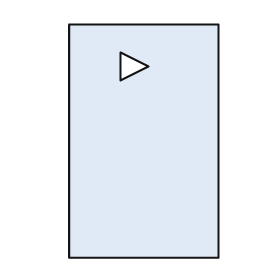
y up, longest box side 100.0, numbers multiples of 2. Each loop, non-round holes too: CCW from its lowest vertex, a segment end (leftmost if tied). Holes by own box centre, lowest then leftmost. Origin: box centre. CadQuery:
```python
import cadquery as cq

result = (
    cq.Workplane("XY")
    .moveTo(-32.0, -50.0)
    .lineTo(32.0, -50.0)
    .lineTo(32.0, 50.0)
    .lineTo(-32.0, 50.0)
    .close()
    .moveTo(-10.0, 26.0)
    .lineTo(2.0, 32.0)
    .lineTo(-10.0, 38.0)
    .close()
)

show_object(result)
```